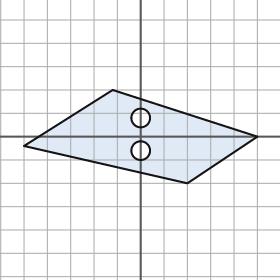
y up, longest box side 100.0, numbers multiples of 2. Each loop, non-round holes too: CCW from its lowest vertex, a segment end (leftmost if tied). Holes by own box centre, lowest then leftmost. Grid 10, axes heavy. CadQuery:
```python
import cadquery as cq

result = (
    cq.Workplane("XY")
    .moveTo(20.0, -20.0)
    .lineTo(50.0, 0.0)
    .lineTo(-12.0, 20.0)
    .lineTo(-50.0, -4.0)
    .close()
    .moveTo(0.0, -6.0)
    .circle(4.0)
    .moveTo(0.0, 8.0)
    .circle(4.0)
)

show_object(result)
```